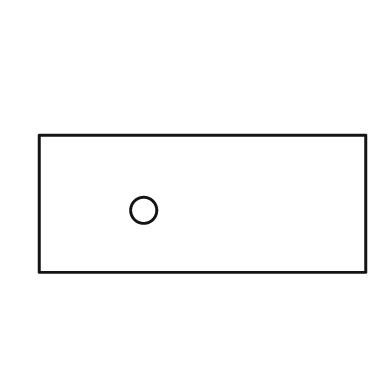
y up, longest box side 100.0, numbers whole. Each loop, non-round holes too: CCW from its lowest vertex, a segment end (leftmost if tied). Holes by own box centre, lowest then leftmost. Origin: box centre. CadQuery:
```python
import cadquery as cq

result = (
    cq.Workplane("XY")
    .moveTo(-50.0, -21.0)
    .lineTo(50.0, -21.0)
    .lineTo(50.0, 21.0)
    .lineTo(-50.0, 21.0)
    .close()
    .moveTo(-18.0, -2.0)
    .circle(4.0)
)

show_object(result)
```